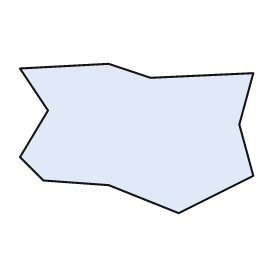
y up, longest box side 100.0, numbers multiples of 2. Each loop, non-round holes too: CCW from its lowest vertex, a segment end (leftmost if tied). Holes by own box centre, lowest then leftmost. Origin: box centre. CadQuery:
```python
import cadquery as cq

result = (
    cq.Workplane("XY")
    .moveTo(18.0, -32.0)
    .lineTo(50.0, -16.0)
    .lineTo(44.0, 6.0)
    .lineTo(50.0, 28.0)
    .lineTo(6.0, 26.0)
    .lineTo(-12.0, 32.0)
    .lineTo(-50.0, 30.0)
    .lineTo(-38.0, 12.0)
    .lineTo(-50.0, -8.0)
    .lineTo(-40.0, -18.0)
    .lineTo(-12.0, -20.0)
    .close()
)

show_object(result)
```